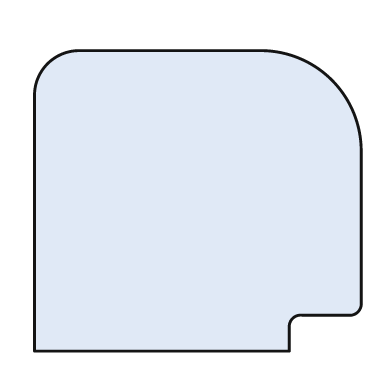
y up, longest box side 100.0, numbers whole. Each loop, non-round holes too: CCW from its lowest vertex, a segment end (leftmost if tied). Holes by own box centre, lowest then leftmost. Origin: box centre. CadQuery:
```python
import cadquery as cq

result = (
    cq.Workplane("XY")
    .moveTo(-50.0, -46.0)
    .lineTo(28.0, -46.0)
    .lineTo(28.0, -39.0)
    .threePointArc((29.0, -36.0), (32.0, -35.0))
    .lineTo(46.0, -35.0)
    .threePointArc((49.0, -34.0), (50.0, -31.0))
    .lineTo(50.0, 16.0)
    .threePointArc((41.0, 37.0), (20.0, 46.0))
    .lineTo(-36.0, 46.0)
    .threePointArc((-46.0, 42.0), (-50.0, 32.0))
    .close()
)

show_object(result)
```